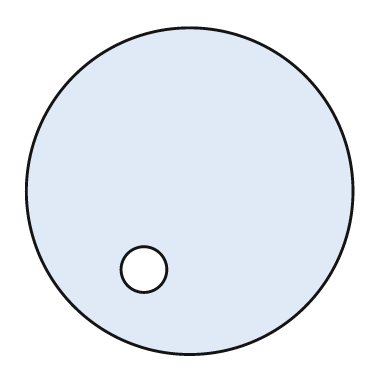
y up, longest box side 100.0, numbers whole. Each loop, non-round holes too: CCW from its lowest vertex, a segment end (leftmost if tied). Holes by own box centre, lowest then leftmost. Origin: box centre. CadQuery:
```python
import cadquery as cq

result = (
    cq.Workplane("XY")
    .moveTo(0.0, 0.0)
    .circle(50.0)
    .moveTo(-14.0, -24.0)
    .circle(7.0)
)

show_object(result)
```